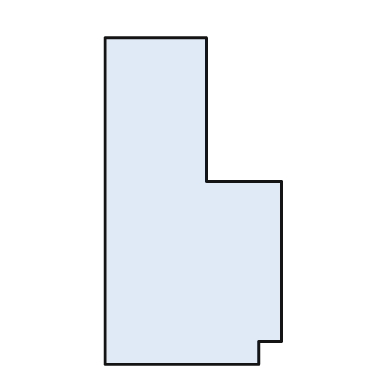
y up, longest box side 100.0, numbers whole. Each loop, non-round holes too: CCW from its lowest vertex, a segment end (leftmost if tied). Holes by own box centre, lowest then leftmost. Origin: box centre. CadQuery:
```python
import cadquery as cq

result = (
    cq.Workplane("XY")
    .moveTo(-27.0, -50.0)
    .lineTo(20.0, -50.0)
    .lineTo(20.0, -43.0)
    .lineTo(27.0, -43.0)
    .lineTo(27.0, 6.0)
    .lineTo(4.0, 6.0)
    .lineTo(4.0, 50.0)
    .lineTo(-27.0, 50.0)
    .close()
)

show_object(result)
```